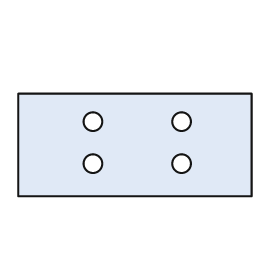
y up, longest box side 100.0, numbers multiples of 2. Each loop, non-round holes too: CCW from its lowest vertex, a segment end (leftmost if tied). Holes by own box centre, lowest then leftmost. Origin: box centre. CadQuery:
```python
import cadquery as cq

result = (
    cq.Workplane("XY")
    .moveTo(-50.0, -22.0)
    .lineTo(50.0, -22.0)
    .lineTo(50.0, 22.0)
    .lineTo(-50.0, 22.0)
    .close()
    .moveTo(-18.0, -8.0)
    .circle(4.0)
    .moveTo(20.0, -8.0)
    .circle(4.0)
    .moveTo(-18.0, 10.0)
    .circle(4.0)
    .moveTo(20.0, 10.0)
    .circle(4.0)
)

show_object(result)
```